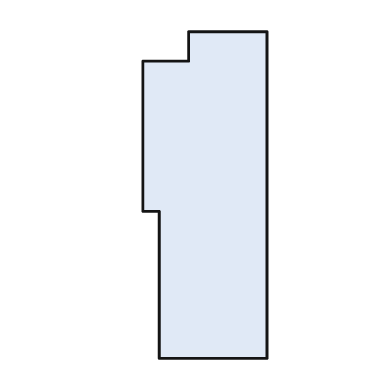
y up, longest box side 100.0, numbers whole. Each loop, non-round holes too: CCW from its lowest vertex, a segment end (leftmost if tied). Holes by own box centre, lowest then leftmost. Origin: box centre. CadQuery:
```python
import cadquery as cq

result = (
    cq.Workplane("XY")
    .moveTo(-14.0, -50.0)
    .lineTo(19.0, -50.0)
    .lineTo(19.0, 50.0)
    .lineTo(-5.0, 50.0)
    .lineTo(-5.0, 41.0)
    .lineTo(-19.0, 41.0)
    .lineTo(-19.0, -5.0)
    .lineTo(-14.0, -5.0)
    .close()
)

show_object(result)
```